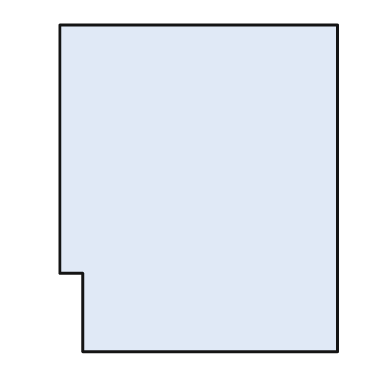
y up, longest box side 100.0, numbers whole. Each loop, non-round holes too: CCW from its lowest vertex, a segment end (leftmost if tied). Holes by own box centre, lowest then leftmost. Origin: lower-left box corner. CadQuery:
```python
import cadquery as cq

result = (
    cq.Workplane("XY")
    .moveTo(7.0, 0.0)
    .lineTo(85.0, 0.0)
    .lineTo(85.0, 100.0)
    .lineTo(0.0, 100.0)
    .lineTo(0.0, 24.0)
    .lineTo(7.0, 24.0)
    .close()
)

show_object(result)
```